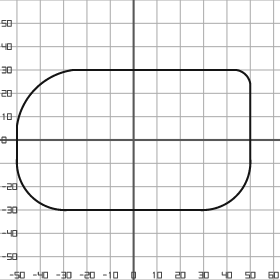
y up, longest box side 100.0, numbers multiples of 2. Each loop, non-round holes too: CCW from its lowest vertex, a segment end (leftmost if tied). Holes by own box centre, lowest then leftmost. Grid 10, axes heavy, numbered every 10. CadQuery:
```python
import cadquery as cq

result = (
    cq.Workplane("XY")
    .moveTo(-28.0, -30.0)
    .lineTo(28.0, -30.0)
    .threePointArc((44.0, -24.0), (50.0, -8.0))
    .lineTo(50.0, 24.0)
    .threePointArc((48.0, 28.0), (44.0, 30.0))
    .lineTo(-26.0, 30.0)
    .threePointArc((-42.0, 22.0), (-50.0, 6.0))
    .lineTo(-50.0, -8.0)
    .threePointArc((-44.0, -24.0), (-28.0, -30.0))
    .close()
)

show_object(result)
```